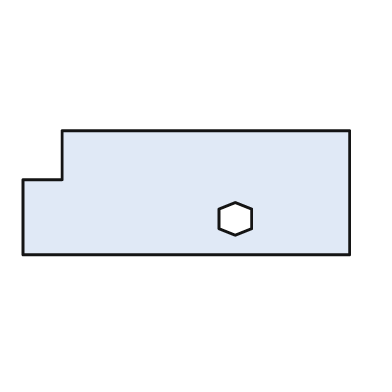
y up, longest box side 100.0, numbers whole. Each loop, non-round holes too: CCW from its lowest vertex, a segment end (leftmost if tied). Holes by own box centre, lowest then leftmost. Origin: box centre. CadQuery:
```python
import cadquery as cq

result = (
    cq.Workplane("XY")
    .moveTo(-50.0, -19.0)
    .lineTo(50.0, -19.0)
    .lineTo(50.0, 19.0)
    .lineTo(-38.0, 19.0)
    .lineTo(-38.0, 4.0)
    .lineTo(-50.0, 4.0)
    .close()
    .moveTo(15.0, -13.0)
    .lineTo(20.0, -11.0)
    .lineTo(20.0, -5.0)
    .lineTo(15.0, -3.0)
    .lineTo(10.0, -5.0)
    .lineTo(10.0, -11.0)
    .close()
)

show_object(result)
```